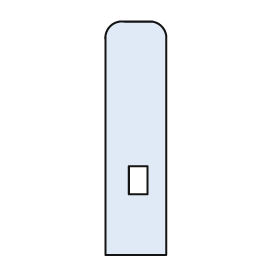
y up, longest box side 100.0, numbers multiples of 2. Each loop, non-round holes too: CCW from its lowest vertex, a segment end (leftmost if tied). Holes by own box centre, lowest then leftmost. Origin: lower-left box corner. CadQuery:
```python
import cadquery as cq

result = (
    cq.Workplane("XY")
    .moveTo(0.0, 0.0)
    .lineTo(26.0, 0.0)
    .lineTo(26.0, 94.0)
    .threePointArc((24.0, 98.0), (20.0, 100.0))
    .lineTo(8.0, 100.0)
    .threePointArc((2.0, 98.0), (0.0, 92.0))
    .close()
    .moveTo(10.0, 26.0)
    .lineTo(18.0, 26.0)
    .lineTo(18.0, 38.0)
    .lineTo(10.0, 38.0)
    .close()
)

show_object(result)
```